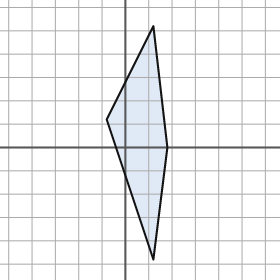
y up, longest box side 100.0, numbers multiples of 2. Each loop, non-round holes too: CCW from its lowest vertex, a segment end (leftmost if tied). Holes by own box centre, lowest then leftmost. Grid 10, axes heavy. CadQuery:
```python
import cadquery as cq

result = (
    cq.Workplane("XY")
    .moveTo(12.0, -48.0)
    .lineTo(18.0, 0.0)
    .lineTo(12.0, 52.0)
    .lineTo(-8.0, 12.0)
    .close()
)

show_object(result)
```